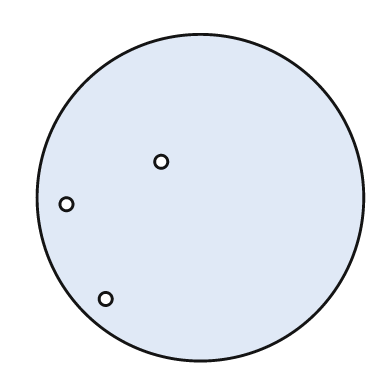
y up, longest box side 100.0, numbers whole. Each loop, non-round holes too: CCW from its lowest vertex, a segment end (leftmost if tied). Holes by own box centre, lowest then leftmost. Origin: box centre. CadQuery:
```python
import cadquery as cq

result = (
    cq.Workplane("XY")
    .moveTo(0.0, 0.0)
    .circle(50.0)
    .moveTo(-29.0, -31.0)
    .circle(2.0)
    .moveTo(-41.0, -2.0)
    .circle(2.0)
    .moveTo(-12.0, 11.0)
    .circle(2.0)
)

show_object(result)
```